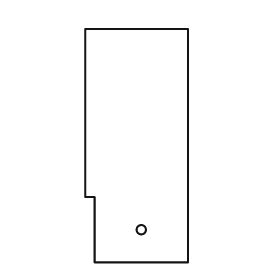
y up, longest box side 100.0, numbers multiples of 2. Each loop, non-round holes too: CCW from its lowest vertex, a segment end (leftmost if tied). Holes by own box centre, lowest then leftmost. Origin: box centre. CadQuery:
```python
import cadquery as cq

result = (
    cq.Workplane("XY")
    .moveTo(-18.0, -50.0)
    .lineTo(22.0, -50.0)
    .lineTo(22.0, 50.0)
    .lineTo(-22.0, 50.0)
    .lineTo(-22.0, -22.0)
    .lineTo(-18.0, -22.0)
    .close()
    .moveTo(2.0, -36.0)
    .circle(2.0)
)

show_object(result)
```